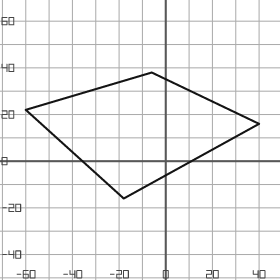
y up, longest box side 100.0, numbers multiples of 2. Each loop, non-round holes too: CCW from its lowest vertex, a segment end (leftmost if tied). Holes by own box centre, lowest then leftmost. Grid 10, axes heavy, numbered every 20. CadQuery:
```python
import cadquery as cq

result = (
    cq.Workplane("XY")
    .moveTo(-18.0, -16.0)
    .lineTo(40.0, 16.0)
    .lineTo(-6.0, 38.0)
    .lineTo(-60.0, 22.0)
    .close()
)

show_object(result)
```